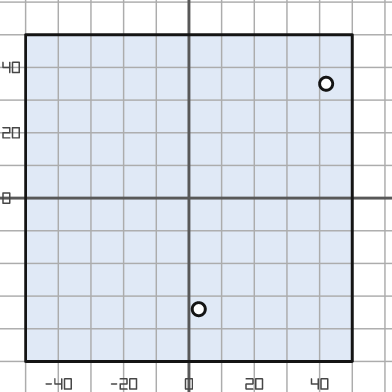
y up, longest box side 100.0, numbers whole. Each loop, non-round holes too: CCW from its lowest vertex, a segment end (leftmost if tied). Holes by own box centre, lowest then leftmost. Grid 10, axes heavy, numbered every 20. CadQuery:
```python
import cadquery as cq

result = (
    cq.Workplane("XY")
    .moveTo(-50.0, -50.0)
    .lineTo(50.0, -50.0)
    .lineTo(50.0, 50.0)
    .lineTo(-50.0, 50.0)
    .close()
    .moveTo(3.0, -34.0)
    .circle(2.0)
    .moveTo(42.0, 35.0)
    .circle(2.0)
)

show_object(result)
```